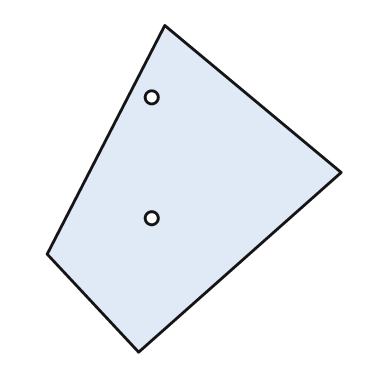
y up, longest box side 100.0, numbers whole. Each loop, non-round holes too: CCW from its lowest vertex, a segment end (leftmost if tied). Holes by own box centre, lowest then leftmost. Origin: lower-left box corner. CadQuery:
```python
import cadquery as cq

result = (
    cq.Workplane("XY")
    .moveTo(28.0, 0.0)
    .lineTo(90.0, 55.0)
    .lineTo(36.0, 100.0)
    .lineTo(0.0, 30.0)
    .close()
    .moveTo(32.0, 41.0)
    .circle(2.0)
    .moveTo(32.0, 78.0)
    .circle(2.0)
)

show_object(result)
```